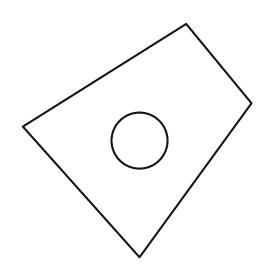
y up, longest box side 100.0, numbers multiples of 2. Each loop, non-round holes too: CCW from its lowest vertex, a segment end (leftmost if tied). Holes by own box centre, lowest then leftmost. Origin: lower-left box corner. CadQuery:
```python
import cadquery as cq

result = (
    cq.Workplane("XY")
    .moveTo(50.0, 0.0)
    .lineTo(98.0, 66.0)
    .lineTo(70.0, 100.0)
    .lineTo(0.0, 56.0)
    .close()
    .moveTo(50.0, 50.0)
    .circle(12.0)
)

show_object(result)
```